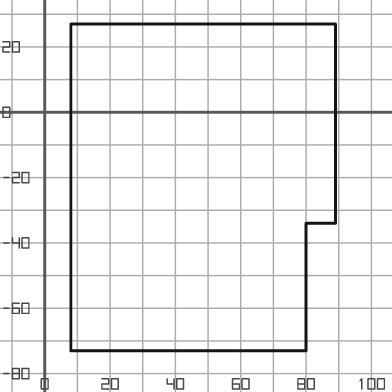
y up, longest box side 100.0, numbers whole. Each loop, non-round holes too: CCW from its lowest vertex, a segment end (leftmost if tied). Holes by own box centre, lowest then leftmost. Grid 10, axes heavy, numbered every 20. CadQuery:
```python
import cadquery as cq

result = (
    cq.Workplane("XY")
    .moveTo(8.0, -73.0)
    .lineTo(80.0, -73.0)
    .lineTo(80.0, -34.0)
    .lineTo(89.0, -34.0)
    .lineTo(89.0, 27.0)
    .lineTo(8.0, 27.0)
    .close()
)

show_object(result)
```